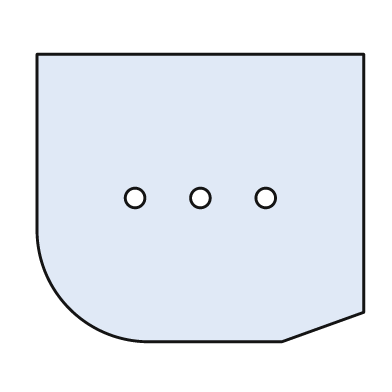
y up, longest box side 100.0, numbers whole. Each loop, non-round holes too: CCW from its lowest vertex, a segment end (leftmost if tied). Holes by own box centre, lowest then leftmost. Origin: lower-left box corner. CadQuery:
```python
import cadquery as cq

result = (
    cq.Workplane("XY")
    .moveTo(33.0, 0.0)
    .lineTo(75.0, 0.0)
    .lineTo(100.0, 9.0)
    .lineTo(100.0, 88.0)
    .lineTo(0.0, 88.0)
    .lineTo(0.0, 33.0)
    .threePointArc((10.0, 10.0), (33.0, 0.0))
    .close()
    .moveTo(30.0, 44.0)
    .circle(3.0)
    .moveTo(50.0, 44.0)
    .circle(3.0)
    .moveTo(70.0, 44.0)
    .circle(3.0)
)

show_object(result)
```